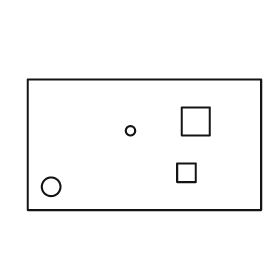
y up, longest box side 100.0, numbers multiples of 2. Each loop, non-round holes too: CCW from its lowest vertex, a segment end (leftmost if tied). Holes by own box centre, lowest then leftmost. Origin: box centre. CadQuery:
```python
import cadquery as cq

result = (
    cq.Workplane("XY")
    .moveTo(-50.0, -28.0)
    .lineTo(50.0, -28.0)
    .lineTo(50.0, 28.0)
    .lineTo(-50.0, 28.0)
    .close()
    .moveTo(-40.0, -18.0)
    .circle(4.0)
    .moveTo(14.0, -16.0)
    .lineTo(22.0, -16.0)
    .lineTo(22.0, -8.0)
    .lineTo(14.0, -8.0)
    .close()
    .moveTo(-6.0, 6.0)
    .circle(2.0)
    .moveTo(16.0, 4.0)
    .lineTo(28.0, 4.0)
    .lineTo(28.0, 16.0)
    .lineTo(16.0, 16.0)
    .close()
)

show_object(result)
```